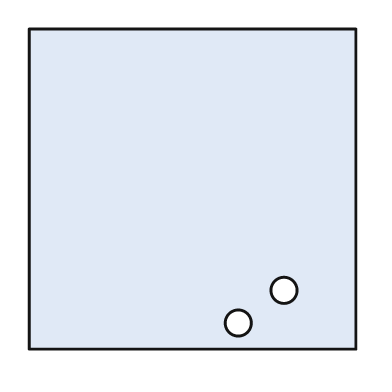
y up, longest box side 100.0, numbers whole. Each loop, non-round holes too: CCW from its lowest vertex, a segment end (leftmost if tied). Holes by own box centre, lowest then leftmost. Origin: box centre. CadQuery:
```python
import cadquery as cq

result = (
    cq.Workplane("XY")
    .moveTo(-50.0, -49.0)
    .lineTo(50.0, -49.0)
    .lineTo(50.0, 49.0)
    .lineTo(-50.0, 49.0)
    .close()
    .moveTo(14.0, -41.0)
    .circle(4.0)
    .moveTo(28.0, -31.0)
    .circle(4.0)
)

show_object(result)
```